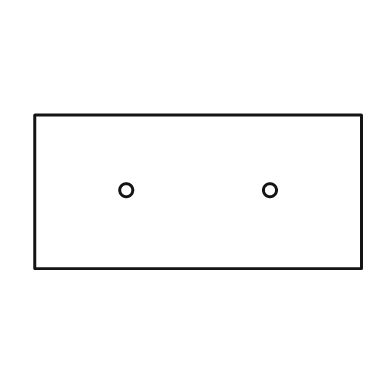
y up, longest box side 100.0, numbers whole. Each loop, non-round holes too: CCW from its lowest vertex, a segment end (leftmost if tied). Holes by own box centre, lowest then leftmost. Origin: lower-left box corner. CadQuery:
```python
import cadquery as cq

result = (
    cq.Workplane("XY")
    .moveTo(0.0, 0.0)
    .lineTo(100.0, 0.0)
    .lineTo(100.0, 47.0)
    .lineTo(0.0, 47.0)
    .close()
    .moveTo(28.0, 24.0)
    .circle(2.0)
    .moveTo(72.0, 24.0)
    .circle(2.0)
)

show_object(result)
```